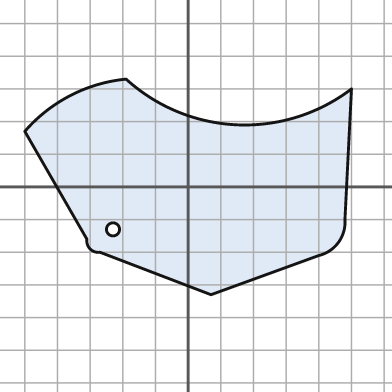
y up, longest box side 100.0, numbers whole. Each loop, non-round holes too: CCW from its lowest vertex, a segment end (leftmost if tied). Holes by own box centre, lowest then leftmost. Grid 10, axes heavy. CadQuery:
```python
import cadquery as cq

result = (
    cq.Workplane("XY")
    .moveTo(7.0, -33.0)
    .lineTo(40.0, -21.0)
    .threePointArc((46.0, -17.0), (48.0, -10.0))
    .lineTo(50.0, 30.0)
    .threePointArc((15.0, 19.0), (-19.0, 33.0))
    .threePointArc((-36.0, 28.0), (-50.0, 17.0))
    .lineTo(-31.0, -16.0)
    .threePointArc((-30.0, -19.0), (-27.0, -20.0))
    .close()
    .moveTo(-23.0, -13.0)
    .circle(2.0)
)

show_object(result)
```